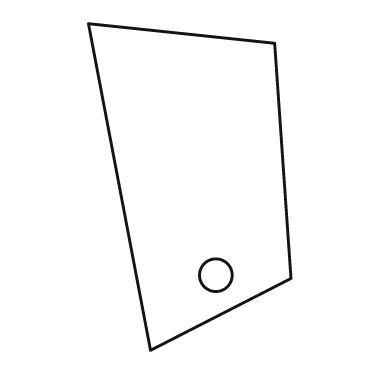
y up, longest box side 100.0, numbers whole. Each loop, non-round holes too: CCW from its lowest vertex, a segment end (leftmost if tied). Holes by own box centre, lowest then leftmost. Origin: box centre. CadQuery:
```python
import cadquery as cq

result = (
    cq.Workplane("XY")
    .moveTo(-12.0, -50.0)
    .lineTo(31.0, -28.0)
    .lineTo(26.0, 44.0)
    .lineTo(-31.0, 50.0)
    .close()
    .moveTo(8.0, -27.0)
    .circle(5.0)
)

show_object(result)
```